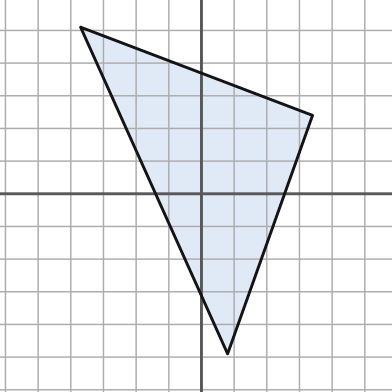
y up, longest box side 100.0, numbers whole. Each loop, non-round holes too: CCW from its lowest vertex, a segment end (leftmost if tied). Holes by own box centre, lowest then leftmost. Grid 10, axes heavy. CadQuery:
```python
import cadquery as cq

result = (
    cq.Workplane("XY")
    .moveTo(8.0, -49.0)
    .lineTo(34.0, 24.0)
    .lineTo(-37.0, 51.0)
    .close()
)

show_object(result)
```